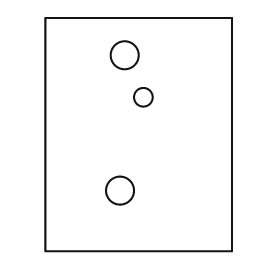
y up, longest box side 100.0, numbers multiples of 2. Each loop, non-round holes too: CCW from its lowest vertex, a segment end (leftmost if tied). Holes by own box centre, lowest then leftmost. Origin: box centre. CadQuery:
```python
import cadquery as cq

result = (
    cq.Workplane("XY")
    .moveTo(-40.0, -50.0)
    .lineTo(40.0, -50.0)
    .lineTo(40.0, 50.0)
    .lineTo(-40.0, 50.0)
    .close()
    .moveTo(-8.0, -24.0)
    .circle(6.0)
    .moveTo(2.0, 16.0)
    .circle(4.0)
    .moveTo(-6.0, 34.0)
    .circle(6.0)
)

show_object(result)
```